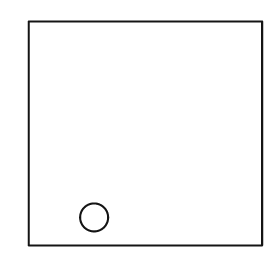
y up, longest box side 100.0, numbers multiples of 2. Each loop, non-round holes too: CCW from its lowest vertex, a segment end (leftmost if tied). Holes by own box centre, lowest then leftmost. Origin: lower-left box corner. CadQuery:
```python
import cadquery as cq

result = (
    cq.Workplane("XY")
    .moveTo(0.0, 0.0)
    .lineTo(100.0, 0.0)
    .lineTo(100.0, 96.0)
    .lineTo(0.0, 96.0)
    .close()
    .moveTo(28.0, 12.0)
    .circle(6.0)
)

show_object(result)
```